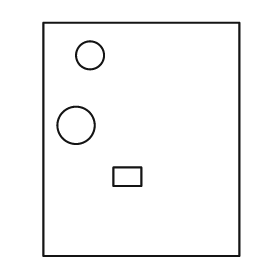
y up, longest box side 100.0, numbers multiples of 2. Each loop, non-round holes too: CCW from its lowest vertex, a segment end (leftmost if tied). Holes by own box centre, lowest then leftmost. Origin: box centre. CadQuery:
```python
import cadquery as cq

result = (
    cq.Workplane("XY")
    .moveTo(-42.0, -50.0)
    .lineTo(42.0, -50.0)
    .lineTo(42.0, 50.0)
    .lineTo(-42.0, 50.0)
    .close()
    .moveTo(-12.0, -20.0)
    .lineTo(0.0, -20.0)
    .lineTo(0.0, -12.0)
    .lineTo(-12.0, -12.0)
    .close()
    .moveTo(-28.0, 6.0)
    .circle(8.0)
    .moveTo(-22.0, 36.0)
    .circle(6.0)
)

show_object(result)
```